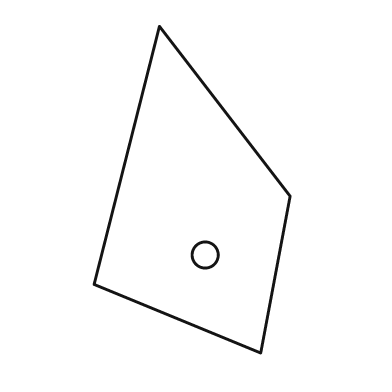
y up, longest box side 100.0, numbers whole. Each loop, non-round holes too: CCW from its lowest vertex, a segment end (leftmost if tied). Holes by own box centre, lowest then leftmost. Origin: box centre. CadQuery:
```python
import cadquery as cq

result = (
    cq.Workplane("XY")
    .moveTo(21.0, -50.0)
    .lineTo(30.0, -2.0)
    .lineTo(-10.0, 50.0)
    .lineTo(-30.0, -29.0)
    .close()
    .moveTo(4.0, -20.0)
    .circle(4.0)
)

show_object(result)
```